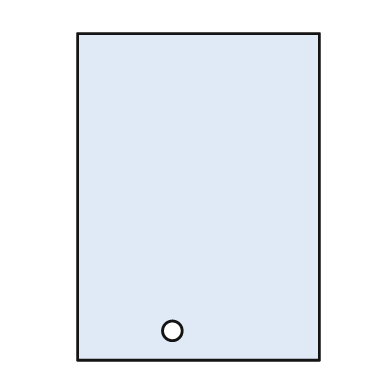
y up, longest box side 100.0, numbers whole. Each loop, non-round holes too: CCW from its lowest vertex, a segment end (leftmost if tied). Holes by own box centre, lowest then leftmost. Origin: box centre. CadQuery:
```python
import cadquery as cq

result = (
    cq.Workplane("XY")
    .moveTo(-37.0, -50.0)
    .lineTo(37.0, -50.0)
    .lineTo(37.0, 50.0)
    .lineTo(-37.0, 50.0)
    .close()
    .moveTo(-8.0, -41.0)
    .circle(3.0)
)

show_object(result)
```